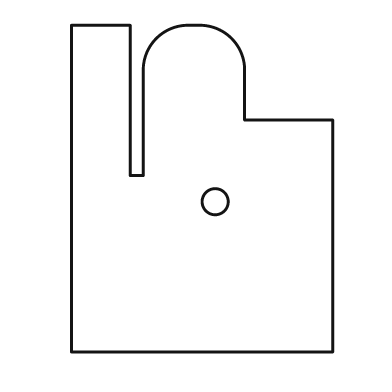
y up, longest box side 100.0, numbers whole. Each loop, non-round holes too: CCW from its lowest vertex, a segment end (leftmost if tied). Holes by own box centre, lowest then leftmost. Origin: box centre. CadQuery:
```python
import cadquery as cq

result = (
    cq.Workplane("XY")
    .moveTo(-40.0, -50.0)
    .lineTo(40.0, -50.0)
    .lineTo(40.0, 21.0)
    .lineTo(13.0, 21.0)
    .lineTo(13.0, 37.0)
    .threePointArc((9.0, 46.0), (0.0, 50.0))
    .lineTo(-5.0, 50.0)
    .threePointArc((-14.0, 46.0), (-18.0, 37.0))
    .lineTo(-18.0, 4.0)
    .lineTo(-22.0, 4.0)
    .lineTo(-22.0, 50.0)
    .lineTo(-40.0, 50.0)
    .close()
    .moveTo(4.0, -4.0)
    .circle(4.0)
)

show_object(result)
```